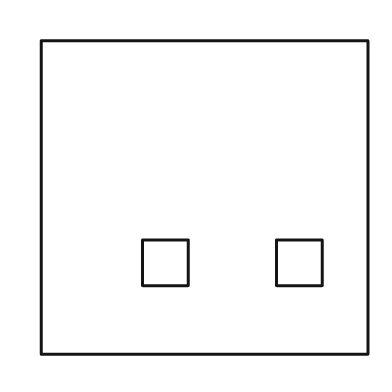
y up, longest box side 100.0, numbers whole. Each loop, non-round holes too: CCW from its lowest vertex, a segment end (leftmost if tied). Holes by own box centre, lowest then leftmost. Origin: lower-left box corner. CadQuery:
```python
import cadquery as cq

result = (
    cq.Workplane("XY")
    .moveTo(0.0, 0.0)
    .lineTo(100.0, 0.0)
    .lineTo(100.0, 96.0)
    .lineTo(0.0, 96.0)
    .close()
    .moveTo(31.0, 21.0)
    .lineTo(45.0, 21.0)
    .lineTo(45.0, 35.0)
    .lineTo(31.0, 35.0)
    .close()
    .moveTo(72.0, 21.0)
    .lineTo(86.0, 21.0)
    .lineTo(86.0, 35.0)
    .lineTo(72.0, 35.0)
    .close()
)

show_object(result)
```